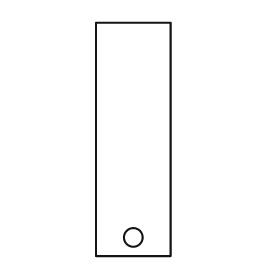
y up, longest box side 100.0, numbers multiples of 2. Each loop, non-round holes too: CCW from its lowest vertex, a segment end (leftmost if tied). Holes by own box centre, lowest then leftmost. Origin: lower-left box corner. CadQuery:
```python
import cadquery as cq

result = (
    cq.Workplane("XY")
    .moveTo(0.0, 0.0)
    .lineTo(32.0, 0.0)
    .lineTo(32.0, 100.0)
    .lineTo(0.0, 100.0)
    .close()
    .moveTo(16.0, 8.0)
    .circle(4.0)
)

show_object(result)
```